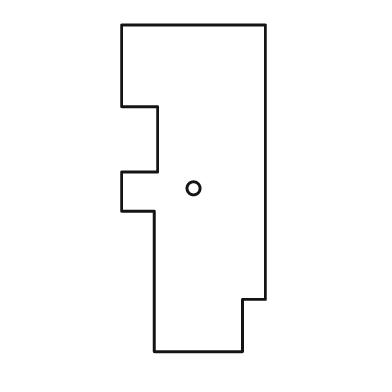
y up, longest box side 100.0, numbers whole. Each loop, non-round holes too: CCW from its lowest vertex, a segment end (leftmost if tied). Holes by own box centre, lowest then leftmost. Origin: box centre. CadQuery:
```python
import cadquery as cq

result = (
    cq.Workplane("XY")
    .moveTo(-12.0, -50.0)
    .lineTo(15.0, -50.0)
    .lineTo(15.0, -34.0)
    .lineTo(22.0, -34.0)
    .lineTo(22.0, 50.0)
    .lineTo(-22.0, 50.0)
    .lineTo(-22.0, 25.0)
    .lineTo(-11.0, 25.0)
    .lineTo(-11.0, 5.0)
    .lineTo(-22.0, 5.0)
    .lineTo(-22.0, -7.0)
    .lineTo(-12.0, -7.0)
    .close()
    .moveTo(0.0, 0.0)
    .circle(2.0)
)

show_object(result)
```